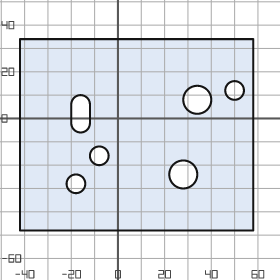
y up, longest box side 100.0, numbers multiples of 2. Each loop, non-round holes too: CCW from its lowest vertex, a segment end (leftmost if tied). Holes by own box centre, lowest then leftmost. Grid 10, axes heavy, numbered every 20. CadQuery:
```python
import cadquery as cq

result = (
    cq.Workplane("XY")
    .moveTo(-42.0, -48.0)
    .lineTo(58.0, -48.0)
    .lineTo(58.0, 34.0)
    .lineTo(-42.0, 34.0)
    .close()
    .moveTo(-18.0, -28.0)
    .circle(4.0)
    .moveTo(28.0, -24.0)
    .circle(6.0)
    .moveTo(-8.0, -16.0)
    .circle(4.0)
    .moveTo(-20.0, -2.0)
    .threePointArc((-16.0, -6.0), (-12.0, -2.0))
    .lineTo(-12.0, 6.0)
    .threePointArc((-16.0, 10.0), (-20.0, 6.0))
    .close()
    .moveTo(34.0, 8.0)
    .circle(6.0)
    .moveTo(50.0, 12.0)
    .circle(4.0)
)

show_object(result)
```